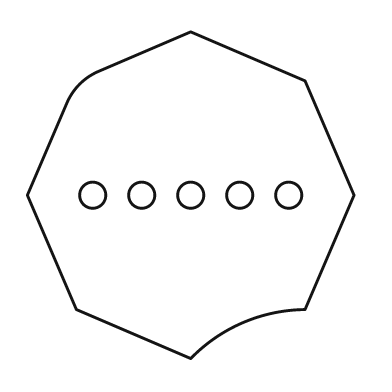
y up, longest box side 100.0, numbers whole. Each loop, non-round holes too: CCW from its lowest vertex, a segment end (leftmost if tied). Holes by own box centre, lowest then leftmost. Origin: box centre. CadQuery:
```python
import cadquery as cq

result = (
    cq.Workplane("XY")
    .moveTo(0.0, -50.0)
    .threePointArc((16.0, -39.0), (35.0, -35.0))
    .lineTo(50.0, 0.0)
    .lineTo(35.0, 35.0)
    .lineTo(0.0, 50.0)
    .lineTo(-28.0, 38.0)
    .threePointArc((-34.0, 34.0), (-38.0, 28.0))
    .lineTo(-50.0, 0.0)
    .lineTo(-35.0, -35.0)
    .close()
    .moveTo(-30.0, 0.0)
    .circle(4.0)
    .moveTo(-15.0, 0.0)
    .circle(4.0)
    .moveTo(0.0, 0.0)
    .circle(4.0)
    .moveTo(15.0, 0.0)
    .circle(4.0)
    .moveTo(30.0, 0.0)
    .circle(4.0)
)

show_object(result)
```